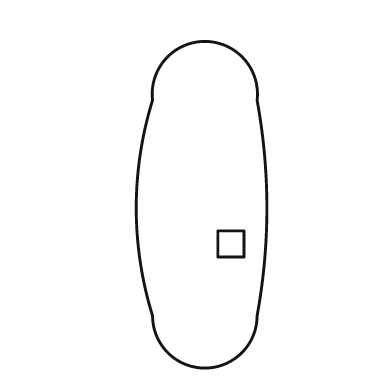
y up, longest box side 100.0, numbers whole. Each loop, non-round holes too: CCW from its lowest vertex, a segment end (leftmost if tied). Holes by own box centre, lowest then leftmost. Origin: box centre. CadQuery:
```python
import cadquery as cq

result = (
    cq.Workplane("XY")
    .moveTo(-15.0, -34.0)
    .threePointArc((1.0, -50.0), (17.0, -34.0))
    .threePointArc((20.0, -1.0), (17.0, 32.0))
    .threePointArc((1.0, 50.0), (-15.0, 32.0))
    .threePointArc((-20.0, -1.0), (-15.0, -34.0))
    .close()
    .moveTo(5.0, -16.0)
    .lineTo(13.0, -16.0)
    .lineTo(13.0, -8.0)
    .lineTo(5.0, -8.0)
    .close()
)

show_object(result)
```